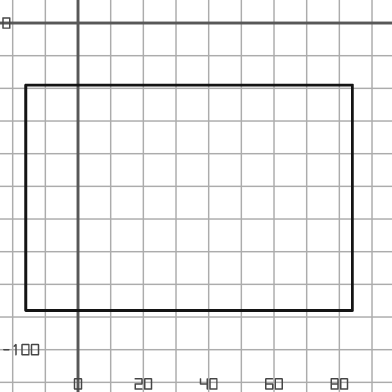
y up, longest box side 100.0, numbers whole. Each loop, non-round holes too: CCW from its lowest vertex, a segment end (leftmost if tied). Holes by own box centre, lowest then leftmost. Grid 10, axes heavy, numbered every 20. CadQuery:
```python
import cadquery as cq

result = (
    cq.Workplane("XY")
    .moveTo(-16.0, -88.0)
    .lineTo(84.0, -88.0)
    .lineTo(84.0, -19.0)
    .lineTo(-16.0, -19.0)
    .close()
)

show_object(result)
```